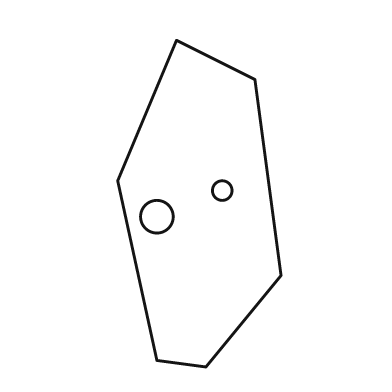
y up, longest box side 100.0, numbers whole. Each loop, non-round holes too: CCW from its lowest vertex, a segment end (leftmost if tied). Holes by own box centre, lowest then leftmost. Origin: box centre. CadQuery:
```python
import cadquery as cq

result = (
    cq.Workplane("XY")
    .moveTo(2.0, -50.0)
    .lineTo(25.0, -22.0)
    .lineTo(17.0, 38.0)
    .lineTo(-7.0, 50.0)
    .lineTo(-25.0, 7.0)
    .lineTo(-13.0, -48.0)
    .close()
    .moveTo(-13.0, -4.0)
    .circle(5.0)
    .moveTo(7.0, 4.0)
    .circle(3.0)
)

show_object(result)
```